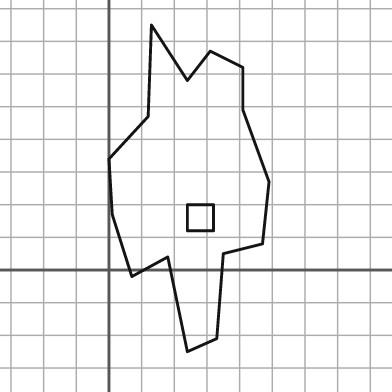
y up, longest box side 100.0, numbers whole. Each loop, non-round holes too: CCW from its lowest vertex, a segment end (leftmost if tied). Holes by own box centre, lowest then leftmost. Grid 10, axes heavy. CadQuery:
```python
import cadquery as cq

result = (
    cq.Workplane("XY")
    .moveTo(24.0, -25.0)
    .lineTo(33.0, -21.0)
    .lineTo(35.0, 5.0)
    .lineTo(47.0, 8.0)
    .lineTo(49.0, 27.0)
    .lineTo(41.0, 49.0)
    .lineTo(41.0, 62.0)
    .lineTo(31.0, 67.0)
    .lineTo(24.0, 58.0)
    .lineTo(13.0, 75.0)
    .lineTo(12.0, 47.0)
    .lineTo(0.0, 34.0)
    .lineTo(1.0, 17.0)
    .lineTo(7.0, -2.0)
    .lineTo(18.0, 4.0)
    .close()
    .moveTo(24.0, 12.0)
    .lineTo(32.0, 12.0)
    .lineTo(32.0, 20.0)
    .lineTo(24.0, 20.0)
    .close()
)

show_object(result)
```